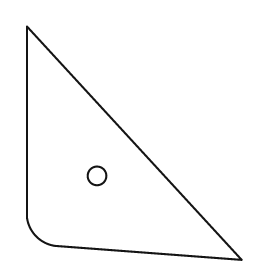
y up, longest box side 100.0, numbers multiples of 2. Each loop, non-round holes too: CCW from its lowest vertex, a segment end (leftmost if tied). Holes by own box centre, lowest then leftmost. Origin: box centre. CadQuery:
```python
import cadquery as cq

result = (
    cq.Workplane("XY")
    .moveTo(46.0, -50.0)
    .lineTo(-46.0, 50.0)
    .lineTo(-46.0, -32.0)
    .threePointArc((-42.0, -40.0), (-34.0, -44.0))
    .close()
    .moveTo(-16.0, -14.0)
    .circle(4.0)
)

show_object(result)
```